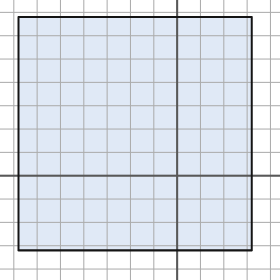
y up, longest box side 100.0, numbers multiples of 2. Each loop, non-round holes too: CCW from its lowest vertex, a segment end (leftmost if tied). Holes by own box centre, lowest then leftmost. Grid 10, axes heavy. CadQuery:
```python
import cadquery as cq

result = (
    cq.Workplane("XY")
    .moveTo(-68.0, -32.0)
    .lineTo(32.0, -32.0)
    .lineTo(32.0, 68.0)
    .lineTo(-68.0, 68.0)
    .close()
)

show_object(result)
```